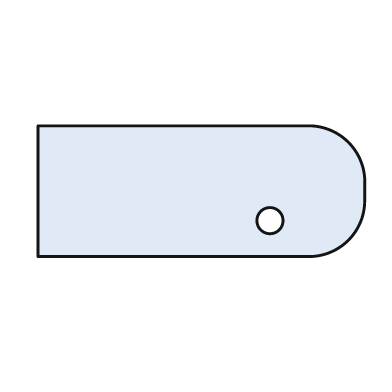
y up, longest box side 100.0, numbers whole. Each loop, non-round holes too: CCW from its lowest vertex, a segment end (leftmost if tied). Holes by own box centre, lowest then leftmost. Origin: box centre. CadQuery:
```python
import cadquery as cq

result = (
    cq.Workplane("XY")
    .moveTo(-50.0, -20.0)
    .lineTo(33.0, -20.0)
    .threePointArc((45.0, -15.0), (50.0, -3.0))
    .lineTo(50.0, 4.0)
    .threePointArc((45.0, 15.0), (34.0, 20.0))
    .lineTo(-50.0, 20.0)
    .close()
    .moveTo(21.0, -9.0)
    .circle(4.0)
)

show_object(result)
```